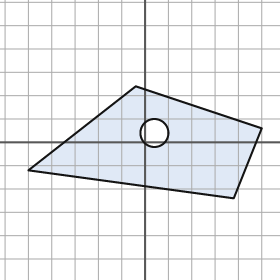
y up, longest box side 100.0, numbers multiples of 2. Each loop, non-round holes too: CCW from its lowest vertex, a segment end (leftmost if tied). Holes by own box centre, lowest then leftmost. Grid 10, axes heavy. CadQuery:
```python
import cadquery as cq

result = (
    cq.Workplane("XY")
    .moveTo(38.0, -24.0)
    .lineTo(50.0, 6.0)
    .lineTo(-4.0, 24.0)
    .lineTo(-50.0, -12.0)
    .close()
    .moveTo(4.0, 4.0)
    .circle(6.0)
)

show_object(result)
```